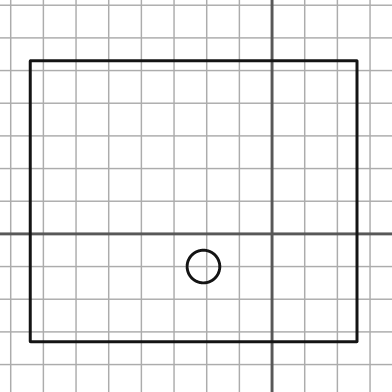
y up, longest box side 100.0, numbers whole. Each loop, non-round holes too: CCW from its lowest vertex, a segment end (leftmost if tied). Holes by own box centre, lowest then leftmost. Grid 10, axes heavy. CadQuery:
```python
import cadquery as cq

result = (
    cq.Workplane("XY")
    .moveTo(-74.0, -33.0)
    .lineTo(26.0, -33.0)
    .lineTo(26.0, 53.0)
    .lineTo(-74.0, 53.0)
    .close()
    .moveTo(-21.0, -10.0)
    .circle(5.0)
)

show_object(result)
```